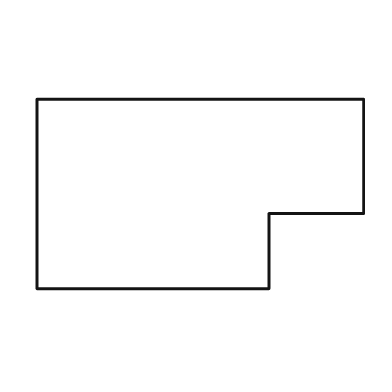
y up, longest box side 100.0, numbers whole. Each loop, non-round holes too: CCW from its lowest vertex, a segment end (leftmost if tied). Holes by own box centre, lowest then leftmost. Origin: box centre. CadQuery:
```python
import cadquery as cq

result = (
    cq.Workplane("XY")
    .moveTo(-50.0, -29.0)
    .lineTo(21.0, -29.0)
    .lineTo(21.0, -6.0)
    .lineTo(50.0, -6.0)
    .lineTo(50.0, 29.0)
    .lineTo(-50.0, 29.0)
    .close()
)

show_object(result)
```